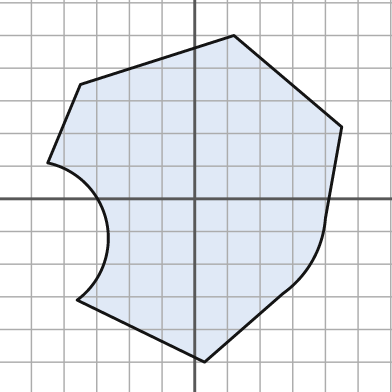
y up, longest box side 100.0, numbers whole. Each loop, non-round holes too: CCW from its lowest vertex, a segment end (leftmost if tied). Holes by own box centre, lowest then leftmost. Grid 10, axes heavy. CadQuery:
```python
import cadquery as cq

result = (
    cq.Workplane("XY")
    .moveTo(3.0, -50.0)
    .lineTo(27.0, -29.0)
    .threePointArc((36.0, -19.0), (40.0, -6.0))
    .lineTo(45.0, 22.0)
    .lineTo(12.0, 50.0)
    .lineTo(-35.0, 35.0)
    .lineTo(-45.0, 11.0)
    .threePointArc((-27.0, -7.0), (-36.0, -31.0))
    .close()
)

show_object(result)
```